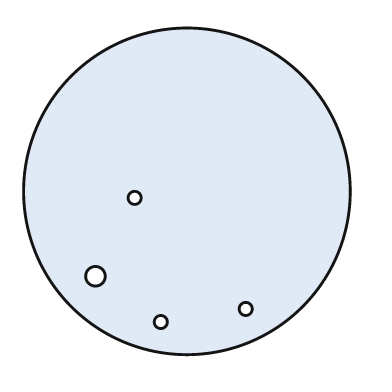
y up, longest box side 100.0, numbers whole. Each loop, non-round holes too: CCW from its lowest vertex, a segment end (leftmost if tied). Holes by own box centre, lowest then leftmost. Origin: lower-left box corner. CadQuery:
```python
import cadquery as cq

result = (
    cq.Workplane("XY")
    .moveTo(50.0, 50.0)
    .circle(50.0)
    .moveTo(42.0, 10.0)
    .circle(2.0)
    .moveTo(68.0, 14.0)
    .circle(2.0)
    .moveTo(22.0, 24.0)
    .circle(3.0)
    .moveTo(34.0, 48.0)
    .circle(2.0)
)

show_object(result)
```